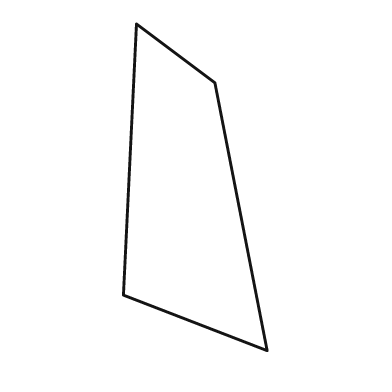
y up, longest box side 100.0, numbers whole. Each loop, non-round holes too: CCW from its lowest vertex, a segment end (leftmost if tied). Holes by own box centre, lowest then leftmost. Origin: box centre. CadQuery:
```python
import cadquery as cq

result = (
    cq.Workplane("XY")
    .moveTo(22.0, -50.0)
    .lineTo(6.0, 32.0)
    .lineTo(-18.0, 50.0)
    .lineTo(-22.0, -33.0)
    .close()
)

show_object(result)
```